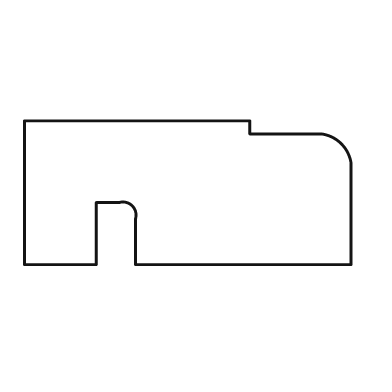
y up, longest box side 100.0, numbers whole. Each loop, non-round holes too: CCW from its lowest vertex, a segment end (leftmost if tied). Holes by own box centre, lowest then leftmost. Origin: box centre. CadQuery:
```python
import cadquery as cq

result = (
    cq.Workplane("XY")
    .moveTo(-50.0, -22.0)
    .lineTo(-28.0, -22.0)
    .lineTo(-28.0, -3.0)
    .lineTo(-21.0, -3.0)
    .threePointArc((-17.0, -4.0), (-16.0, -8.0))
    .lineTo(-16.0, -22.0)
    .lineTo(50.0, -22.0)
    .lineTo(50.0, 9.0)
    .threePointArc((47.0, 15.0), (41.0, 18.0))
    .lineTo(19.0, 18.0)
    .lineTo(19.0, 22.0)
    .lineTo(-50.0, 22.0)
    .close()
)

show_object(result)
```